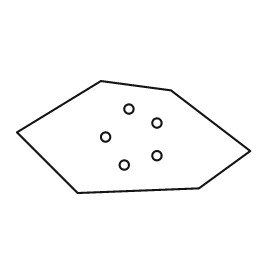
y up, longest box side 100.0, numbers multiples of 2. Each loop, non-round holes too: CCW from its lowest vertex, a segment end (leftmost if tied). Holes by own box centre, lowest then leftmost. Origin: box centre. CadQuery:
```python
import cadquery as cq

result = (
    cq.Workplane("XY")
    .moveTo(-24.0, -24.0)
    .lineTo(28.0, -22.0)
    .lineTo(50.0, -6.0)
    .lineTo(16.0, 20.0)
    .lineTo(-14.0, 24.0)
    .lineTo(-50.0, 2.0)
    .close()
    .moveTo(-4.0, -12.0)
    .circle(2.0)
    .moveTo(10.0, -8.0)
    .circle(2.0)
    .moveTo(-12.0, 0.0)
    .circle(2.0)
    .moveTo(10.0, 6.0)
    .circle(2.0)
    .moveTo(-2.0, 12.0)
    .circle(2.0)
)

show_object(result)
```